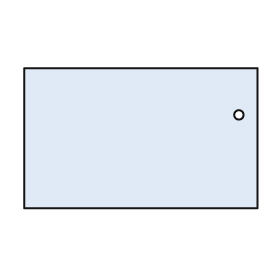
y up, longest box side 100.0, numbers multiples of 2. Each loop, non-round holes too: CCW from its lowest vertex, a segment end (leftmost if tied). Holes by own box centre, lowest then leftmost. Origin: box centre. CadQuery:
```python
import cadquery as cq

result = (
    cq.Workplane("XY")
    .moveTo(-50.0, -30.0)
    .lineTo(50.0, -30.0)
    .lineTo(50.0, 30.0)
    .lineTo(-50.0, 30.0)
    .close()
    .moveTo(42.0, 10.0)
    .circle(2.0)
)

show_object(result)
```